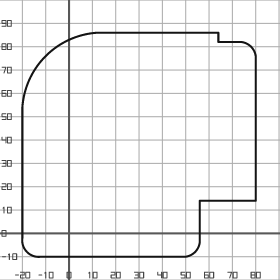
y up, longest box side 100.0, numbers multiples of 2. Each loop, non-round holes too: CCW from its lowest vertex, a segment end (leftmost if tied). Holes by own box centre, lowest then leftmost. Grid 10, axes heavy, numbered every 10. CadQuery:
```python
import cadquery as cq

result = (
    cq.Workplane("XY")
    .moveTo(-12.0, -10.0)
    .lineTo(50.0, -10.0)
    .threePointArc((54.0, -8.0), (56.0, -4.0))
    .lineTo(56.0, 14.0)
    .lineTo(80.0, 14.0)
    .lineTo(80.0, 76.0)
    .threePointArc((78.0, 80.0), (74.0, 82.0))
    .lineTo(64.0, 82.0)
    .lineTo(64.0, 86.0)
    .lineTo(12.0, 86.0)
    .threePointArc((-10.0, 76.0), (-20.0, 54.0))
    .lineTo(-20.0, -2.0)
    .threePointArc((-18.0, -8.0), (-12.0, -10.0))
    .close()
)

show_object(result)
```